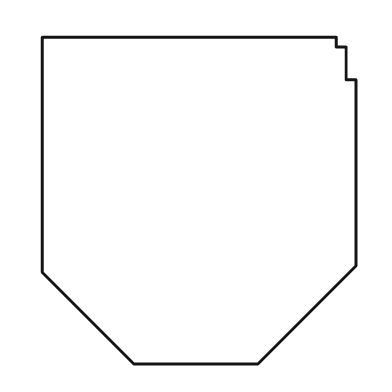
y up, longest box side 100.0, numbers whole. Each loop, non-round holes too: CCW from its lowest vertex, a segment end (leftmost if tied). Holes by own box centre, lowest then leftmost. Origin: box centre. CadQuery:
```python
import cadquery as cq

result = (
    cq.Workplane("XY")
    .moveTo(-20.0, -50.0)
    .lineTo(18.0, -50.0)
    .lineTo(48.0, -20.0)
    .lineTo(48.0, 37.0)
    .lineTo(45.0, 37.0)
    .lineTo(45.0, 47.0)
    .lineTo(42.0, 47.0)
    .lineTo(42.0, 50.0)
    .lineTo(-48.0, 50.0)
    .lineTo(-48.0, -22.0)
    .close()
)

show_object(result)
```